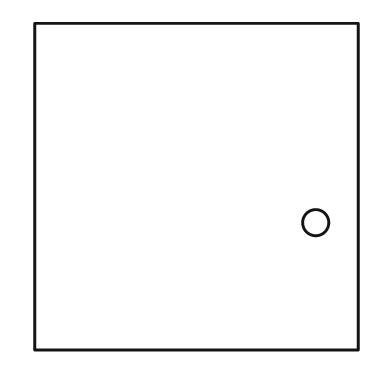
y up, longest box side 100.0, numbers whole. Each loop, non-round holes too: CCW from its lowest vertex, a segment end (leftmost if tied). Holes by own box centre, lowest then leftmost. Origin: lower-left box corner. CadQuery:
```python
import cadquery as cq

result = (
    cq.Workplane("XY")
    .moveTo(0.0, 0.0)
    .lineTo(99.0, 0.0)
    .lineTo(99.0, 100.0)
    .lineTo(0.0, 100.0)
    .close()
    .moveTo(86.0, 39.0)
    .circle(4.0)
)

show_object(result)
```